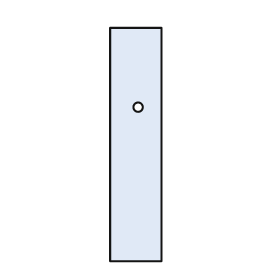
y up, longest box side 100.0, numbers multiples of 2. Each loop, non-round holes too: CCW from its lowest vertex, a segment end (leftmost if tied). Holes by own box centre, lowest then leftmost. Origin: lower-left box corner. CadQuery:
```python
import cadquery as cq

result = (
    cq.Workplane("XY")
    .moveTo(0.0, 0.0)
    .lineTo(22.0, 0.0)
    .lineTo(22.0, 100.0)
    .lineTo(0.0, 100.0)
    .close()
    .moveTo(12.0, 66.0)
    .circle(2.0)
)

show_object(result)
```